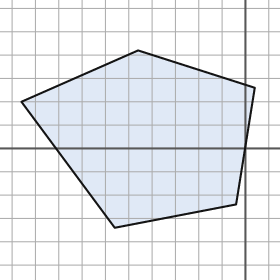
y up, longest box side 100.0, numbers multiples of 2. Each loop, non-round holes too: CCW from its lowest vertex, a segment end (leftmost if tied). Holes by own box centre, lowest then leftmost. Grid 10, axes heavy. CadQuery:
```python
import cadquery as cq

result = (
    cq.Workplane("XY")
    .moveTo(-56.0, -34.0)
    .lineTo(-4.0, -24.0)
    .lineTo(4.0, 26.0)
    .lineTo(-46.0, 42.0)
    .lineTo(-96.0, 20.0)
    .close()
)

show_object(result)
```